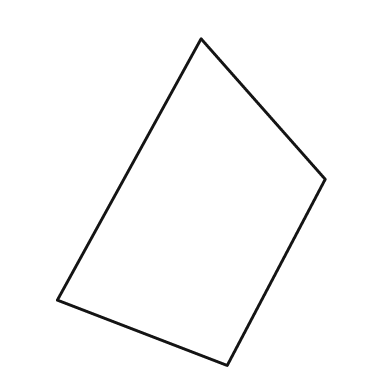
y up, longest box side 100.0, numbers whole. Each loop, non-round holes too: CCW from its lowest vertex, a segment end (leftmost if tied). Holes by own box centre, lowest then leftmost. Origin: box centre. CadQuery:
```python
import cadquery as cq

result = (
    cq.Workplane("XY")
    .moveTo(11.0, -50.0)
    .lineTo(41.0, 7.0)
    .lineTo(3.0, 50.0)
    .lineTo(-41.0, -30.0)
    .close()
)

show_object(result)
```